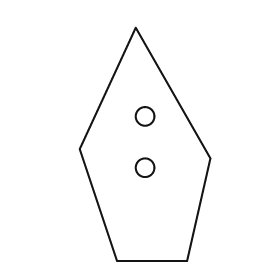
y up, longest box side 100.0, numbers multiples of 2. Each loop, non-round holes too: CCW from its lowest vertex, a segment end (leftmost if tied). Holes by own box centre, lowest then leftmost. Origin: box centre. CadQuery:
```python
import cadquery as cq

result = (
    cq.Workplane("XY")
    .moveTo(-12.0, -50.0)
    .lineTo(18.0, -50.0)
    .lineTo(28.0, -6.0)
    .lineTo(-4.0, 50.0)
    .lineTo(-28.0, -2.0)
    .close()
    .moveTo(0.0, -10.0)
    .circle(4.0)
    .moveTo(0.0, 12.0)
    .circle(4.0)
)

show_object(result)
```